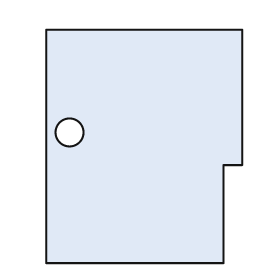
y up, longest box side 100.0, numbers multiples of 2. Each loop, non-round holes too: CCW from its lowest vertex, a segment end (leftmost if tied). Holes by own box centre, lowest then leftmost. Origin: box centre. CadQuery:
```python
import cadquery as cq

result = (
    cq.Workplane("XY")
    .moveTo(-42.0, -50.0)
    .lineTo(34.0, -50.0)
    .lineTo(34.0, -8.0)
    .lineTo(42.0, -8.0)
    .lineTo(42.0, 50.0)
    .lineTo(-42.0, 50.0)
    .close()
    .moveTo(-32.0, 6.0)
    .circle(6.0)
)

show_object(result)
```